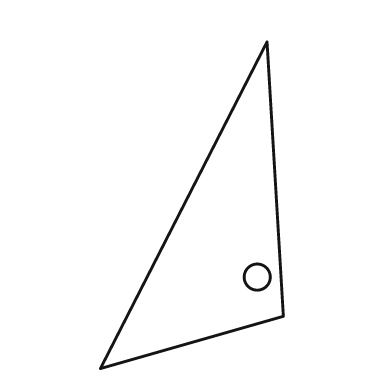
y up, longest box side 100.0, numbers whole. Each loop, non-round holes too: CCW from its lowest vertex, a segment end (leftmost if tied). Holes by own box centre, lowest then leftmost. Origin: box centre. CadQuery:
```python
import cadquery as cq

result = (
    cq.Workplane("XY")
    .moveTo(-28.0, -50.0)
    .lineTo(28.0, -34.0)
    .lineTo(23.0, 50.0)
    .close()
    .moveTo(20.0, -22.0)
    .circle(4.0)
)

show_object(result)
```